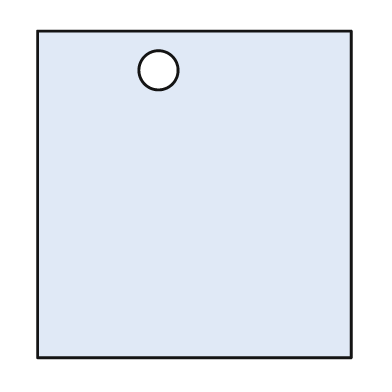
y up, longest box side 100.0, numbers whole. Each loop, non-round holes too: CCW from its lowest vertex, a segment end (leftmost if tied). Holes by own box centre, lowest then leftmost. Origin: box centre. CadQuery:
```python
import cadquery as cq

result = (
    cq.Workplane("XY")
    .moveTo(-48.0, -50.0)
    .lineTo(48.0, -50.0)
    .lineTo(48.0, 50.0)
    .lineTo(-48.0, 50.0)
    .close()
    .moveTo(-11.0, 38.0)
    .circle(6.0)
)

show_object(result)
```